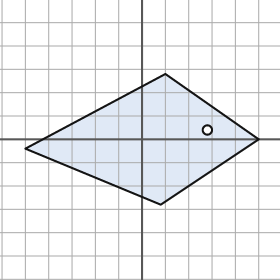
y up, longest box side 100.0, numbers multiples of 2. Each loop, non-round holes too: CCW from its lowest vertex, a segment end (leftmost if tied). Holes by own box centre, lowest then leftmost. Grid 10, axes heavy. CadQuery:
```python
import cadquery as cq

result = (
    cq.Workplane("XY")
    .moveTo(8.0, -28.0)
    .lineTo(50.0, 0.0)
    .lineTo(10.0, 28.0)
    .lineTo(-50.0, -4.0)
    .close()
    .moveTo(28.0, 4.0)
    .circle(2.0)
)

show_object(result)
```